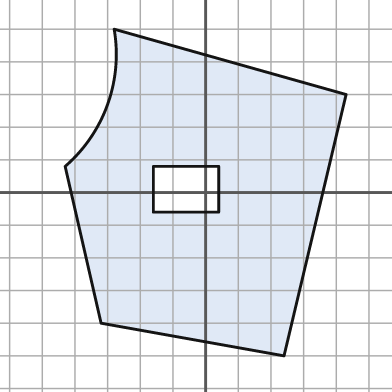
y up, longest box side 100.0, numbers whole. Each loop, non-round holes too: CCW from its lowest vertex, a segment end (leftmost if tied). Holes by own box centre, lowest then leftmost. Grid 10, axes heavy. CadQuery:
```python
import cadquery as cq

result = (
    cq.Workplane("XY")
    .moveTo(24.0, -50.0)
    .lineTo(43.0, 30.0)
    .lineTo(-28.0, 50.0)
    .threePointArc((-30.0, 27.0), (-43.0, 8.0))
    .lineTo(-32.0, -40.0)
    .close()
    .moveTo(-16.0, -6.0)
    .lineTo(4.0, -6.0)
    .lineTo(4.0, 8.0)
    .lineTo(-16.0, 8.0)
    .close()
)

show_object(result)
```